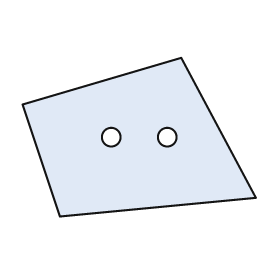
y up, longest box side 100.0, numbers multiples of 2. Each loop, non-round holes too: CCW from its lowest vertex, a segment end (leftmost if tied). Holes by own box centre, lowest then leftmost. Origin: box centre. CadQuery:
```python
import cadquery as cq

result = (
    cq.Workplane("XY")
    .moveTo(-34.0, -34.0)
    .lineTo(50.0, -26.0)
    .lineTo(18.0, 34.0)
    .lineTo(-50.0, 14.0)
    .close()
    .moveTo(-12.0, 0.0)
    .circle(4.0)
    .moveTo(12.0, 0.0)
    .circle(4.0)
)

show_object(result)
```